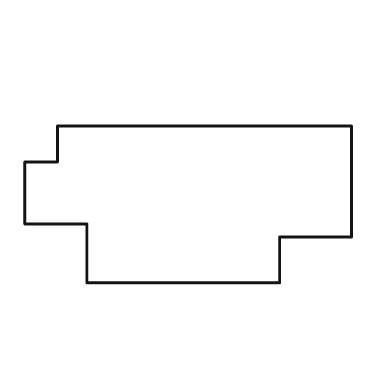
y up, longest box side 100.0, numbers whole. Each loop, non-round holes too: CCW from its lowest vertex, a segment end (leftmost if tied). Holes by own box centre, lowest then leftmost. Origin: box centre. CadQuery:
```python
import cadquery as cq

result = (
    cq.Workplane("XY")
    .moveTo(-31.0, -24.0)
    .lineTo(28.0, -24.0)
    .lineTo(28.0, -10.0)
    .lineTo(50.0, -10.0)
    .lineTo(50.0, 24.0)
    .lineTo(-40.0, 24.0)
    .lineTo(-40.0, 13.0)
    .lineTo(-50.0, 13.0)
    .lineTo(-50.0, -6.0)
    .lineTo(-31.0, -6.0)
    .close()
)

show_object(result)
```